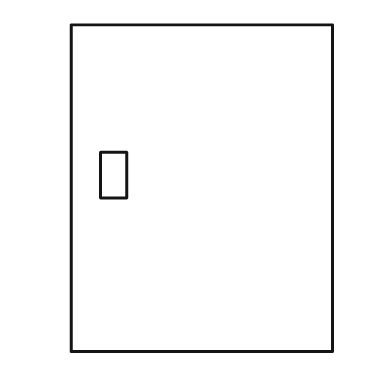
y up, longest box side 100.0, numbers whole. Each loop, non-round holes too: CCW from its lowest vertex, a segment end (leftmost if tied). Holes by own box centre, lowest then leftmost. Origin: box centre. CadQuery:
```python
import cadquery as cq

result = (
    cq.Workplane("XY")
    .moveTo(-40.0, -50.0)
    .lineTo(40.0, -50.0)
    .lineTo(40.0, 50.0)
    .lineTo(-40.0, 50.0)
    .close()
    .moveTo(-31.0, -3.0)
    .lineTo(-23.0, -3.0)
    .lineTo(-23.0, 11.0)
    .lineTo(-31.0, 11.0)
    .close()
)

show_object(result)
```